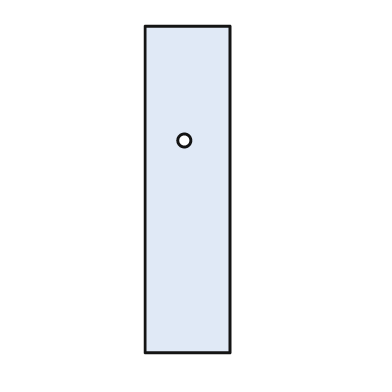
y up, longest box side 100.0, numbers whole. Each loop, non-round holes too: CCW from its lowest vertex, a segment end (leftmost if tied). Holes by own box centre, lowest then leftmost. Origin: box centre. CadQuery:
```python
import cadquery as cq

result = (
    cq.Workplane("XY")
    .moveTo(-13.0, -50.0)
    .lineTo(13.0, -50.0)
    .lineTo(13.0, 50.0)
    .lineTo(-13.0, 50.0)
    .close()
    .moveTo(-1.0, 15.0)
    .circle(2.0)
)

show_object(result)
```